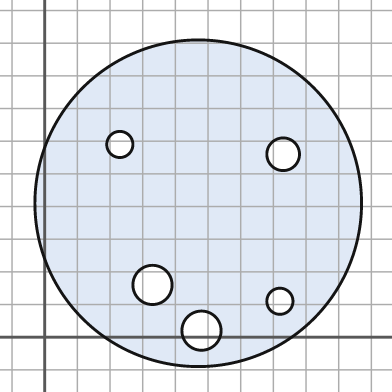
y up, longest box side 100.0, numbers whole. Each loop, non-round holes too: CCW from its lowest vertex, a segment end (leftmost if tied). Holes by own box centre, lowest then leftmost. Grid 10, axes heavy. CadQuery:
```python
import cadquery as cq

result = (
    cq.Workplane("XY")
    .moveTo(47.0, 41.0)
    .circle(50.0)
    .moveTo(48.0, 2.0)
    .circle(6.0)
    .moveTo(72.0, 11.0)
    .circle(4.0)
    .moveTo(33.0, 16.0)
    .circle(6.0)
    .moveTo(73.0, 56.0)
    .circle(5.0)
    .moveTo(23.0, 59.0)
    .circle(4.0)
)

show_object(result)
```